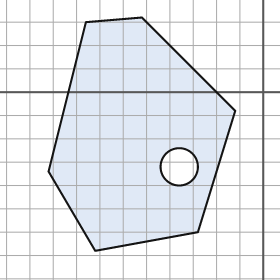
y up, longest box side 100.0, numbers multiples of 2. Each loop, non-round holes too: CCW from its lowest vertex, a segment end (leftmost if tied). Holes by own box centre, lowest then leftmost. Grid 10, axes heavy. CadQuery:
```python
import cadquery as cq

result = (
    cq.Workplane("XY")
    .moveTo(-72.0, -68.0)
    .lineTo(-28.0, -60.0)
    .lineTo(-12.0, -8.0)
    .lineTo(-52.0, 32.0)
    .lineTo(-76.0, 30.0)
    .lineTo(-92.0, -34.0)
    .close()
    .moveTo(-36.0, -32.0)
    .circle(8.0)
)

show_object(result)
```